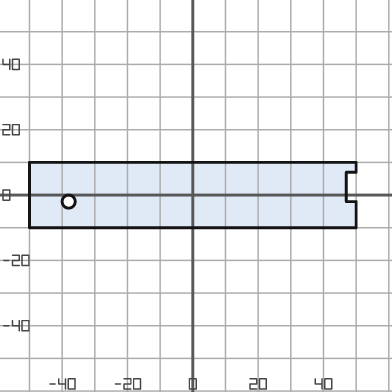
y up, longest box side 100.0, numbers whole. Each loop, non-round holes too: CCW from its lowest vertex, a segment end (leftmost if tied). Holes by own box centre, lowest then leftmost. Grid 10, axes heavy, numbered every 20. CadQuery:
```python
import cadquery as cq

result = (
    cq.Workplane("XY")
    .moveTo(-50.0, -10.0)
    .lineTo(50.0, -10.0)
    .lineTo(50.0, -2.0)
    .lineTo(47.0, -2.0)
    .lineTo(47.0, 7.0)
    .lineTo(50.0, 7.0)
    .lineTo(50.0, 10.0)
    .lineTo(-50.0, 10.0)
    .close()
    .moveTo(-38.0, -2.0)
    .circle(2.0)
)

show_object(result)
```